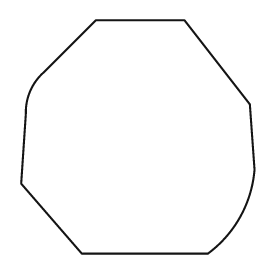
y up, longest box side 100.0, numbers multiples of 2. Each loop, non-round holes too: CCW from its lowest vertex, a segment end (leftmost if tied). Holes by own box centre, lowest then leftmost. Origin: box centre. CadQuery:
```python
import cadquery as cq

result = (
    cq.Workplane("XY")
    .moveTo(-24.0, -50.0)
    .lineTo(30.0, -50.0)
    .threePointArc((44.0, -34.0), (50.0, -14.0))
    .lineTo(48.0, 14.0)
    .lineTo(20.0, 50.0)
    .lineTo(-18.0, 50.0)
    .lineTo(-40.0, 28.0)
    .threePointArc((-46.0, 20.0), (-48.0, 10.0))
    .lineTo(-50.0, -20.0)
    .close()
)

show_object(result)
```